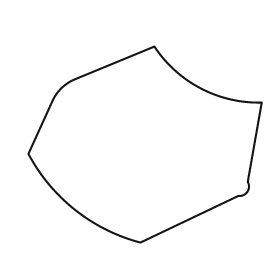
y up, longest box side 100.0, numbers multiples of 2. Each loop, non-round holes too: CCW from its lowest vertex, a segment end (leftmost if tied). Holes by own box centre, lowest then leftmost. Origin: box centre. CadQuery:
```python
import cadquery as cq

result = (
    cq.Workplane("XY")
    .moveTo(-2.0, -42.0)
    .lineTo(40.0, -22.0)
    .threePointArc((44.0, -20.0), (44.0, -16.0))
    .lineTo(50.0, 18.0)
    .threePointArc((24.0, 24.0), (4.0, 42.0))
    .lineTo(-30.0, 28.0)
    .threePointArc((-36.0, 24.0), (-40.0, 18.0))
    .lineTo(-50.0, -4.0)
    .threePointArc((-30.0, -28.0), (-2.0, -42.0))
    .close()
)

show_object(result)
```